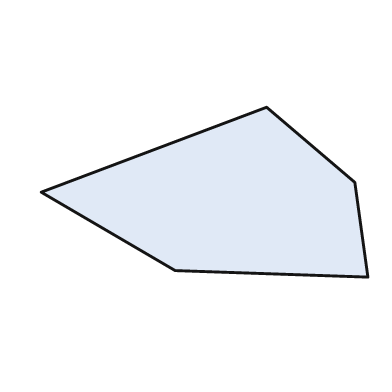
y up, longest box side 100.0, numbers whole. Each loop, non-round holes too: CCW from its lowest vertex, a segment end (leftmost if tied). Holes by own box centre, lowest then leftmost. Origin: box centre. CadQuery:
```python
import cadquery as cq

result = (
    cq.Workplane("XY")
    .moveTo(50.0, -26.0)
    .lineTo(46.0, 3.0)
    .lineTo(19.0, 26.0)
    .lineTo(-50.0, 0.0)
    .lineTo(-9.0, -24.0)
    .close()
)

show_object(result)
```